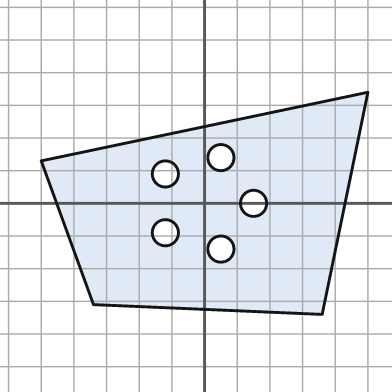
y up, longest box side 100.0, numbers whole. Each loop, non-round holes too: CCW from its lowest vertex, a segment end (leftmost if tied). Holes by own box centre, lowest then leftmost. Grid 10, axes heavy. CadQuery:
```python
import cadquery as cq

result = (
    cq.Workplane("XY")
    .moveTo(36.0, -34.0)
    .lineTo(50.0, 34.0)
    .lineTo(-50.0, 13.0)
    .lineTo(-34.0, -31.0)
    .close()
    .moveTo(5.0, -14.0)
    .circle(4.0)
    .moveTo(-12.0, -9.0)
    .circle(4.0)
    .moveTo(15.0, 0.0)
    .circle(4.0)
    .moveTo(-12.0, 9.0)
    .circle(4.0)
    .moveTo(5.0, 14.0)
    .circle(4.0)
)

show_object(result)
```